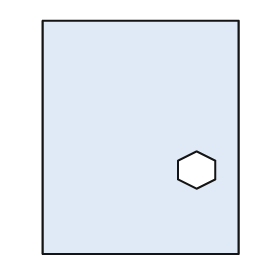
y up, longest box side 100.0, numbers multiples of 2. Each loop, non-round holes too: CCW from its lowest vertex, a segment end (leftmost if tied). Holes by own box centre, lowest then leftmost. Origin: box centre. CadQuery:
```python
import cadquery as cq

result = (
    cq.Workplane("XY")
    .moveTo(-42.0, -50.0)
    .lineTo(42.0, -50.0)
    .lineTo(42.0, 50.0)
    .lineTo(-42.0, 50.0)
    .close()
    .moveTo(24.0, -22.0)
    .lineTo(32.0, -18.0)
    .lineTo(32.0, -10.0)
    .lineTo(24.0, -6.0)
    .lineTo(16.0, -10.0)
    .lineTo(16.0, -18.0)
    .close()
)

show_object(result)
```